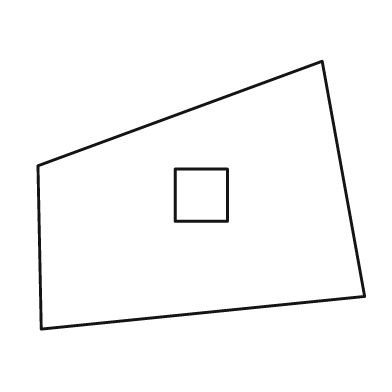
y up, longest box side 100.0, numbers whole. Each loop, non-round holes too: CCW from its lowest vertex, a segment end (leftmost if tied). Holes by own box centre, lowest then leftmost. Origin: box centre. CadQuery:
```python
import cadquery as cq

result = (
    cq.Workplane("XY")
    .moveTo(-49.0, -41.0)
    .lineTo(50.0, -31.0)
    .lineTo(37.0, 41.0)
    .lineTo(-50.0, 9.0)
    .close()
    .moveTo(-8.0, -8.0)
    .lineTo(8.0, -8.0)
    .lineTo(8.0, 8.0)
    .lineTo(-8.0, 8.0)
    .close()
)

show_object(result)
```